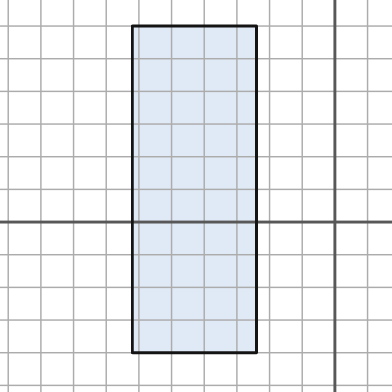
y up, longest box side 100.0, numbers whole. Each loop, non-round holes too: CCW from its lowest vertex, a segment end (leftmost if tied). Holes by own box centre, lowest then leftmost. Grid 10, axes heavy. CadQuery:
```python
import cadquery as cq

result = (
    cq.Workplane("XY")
    .moveTo(-62.0, -40.0)
    .lineTo(-24.0, -40.0)
    .lineTo(-24.0, 60.0)
    .lineTo(-62.0, 60.0)
    .close()
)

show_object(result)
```